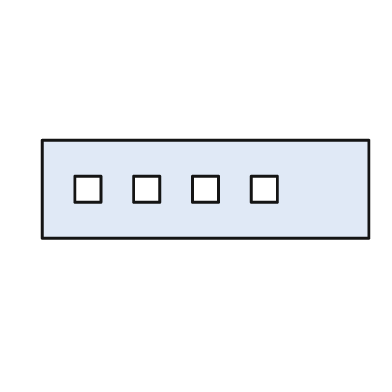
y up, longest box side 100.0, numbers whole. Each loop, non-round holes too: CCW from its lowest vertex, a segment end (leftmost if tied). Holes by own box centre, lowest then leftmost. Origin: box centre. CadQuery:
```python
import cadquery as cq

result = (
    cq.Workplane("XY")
    .moveTo(-50.0, -15.0)
    .lineTo(50.0, -15.0)
    .lineTo(50.0, 15.0)
    .lineTo(-50.0, 15.0)
    .close()
    .moveTo(-40.0, -4.0)
    .lineTo(-32.0, -4.0)
    .lineTo(-32.0, 4.0)
    .lineTo(-40.0, 4.0)
    .close()
    .moveTo(-22.0, -4.0)
    .lineTo(-14.0, -4.0)
    .lineTo(-14.0, 4.0)
    .lineTo(-22.0, 4.0)
    .close()
    .moveTo(-4.0, -4.0)
    .lineTo(4.0, -4.0)
    .lineTo(4.0, 4.0)
    .lineTo(-4.0, 4.0)
    .close()
    .moveTo(14.0, -4.0)
    .lineTo(22.0, -4.0)
    .lineTo(22.0, 4.0)
    .lineTo(14.0, 4.0)
    .close()
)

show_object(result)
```